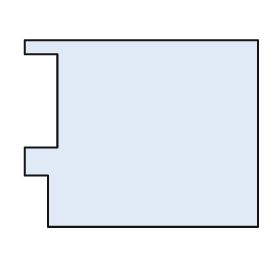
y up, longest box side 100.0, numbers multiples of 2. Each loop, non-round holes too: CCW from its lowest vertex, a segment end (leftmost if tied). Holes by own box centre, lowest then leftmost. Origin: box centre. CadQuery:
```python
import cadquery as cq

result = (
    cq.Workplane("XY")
    .moveTo(-40.0, -40.0)
    .lineTo(50.0, -40.0)
    .lineTo(50.0, 40.0)
    .lineTo(-50.0, 40.0)
    .lineTo(-50.0, 34.0)
    .lineTo(-36.0, 34.0)
    .lineTo(-36.0, -6.0)
    .lineTo(-50.0, -6.0)
    .lineTo(-50.0, -18.0)
    .lineTo(-40.0, -18.0)
    .close()
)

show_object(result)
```